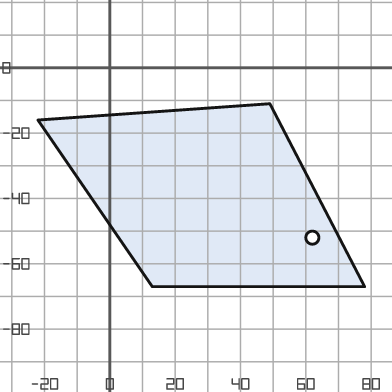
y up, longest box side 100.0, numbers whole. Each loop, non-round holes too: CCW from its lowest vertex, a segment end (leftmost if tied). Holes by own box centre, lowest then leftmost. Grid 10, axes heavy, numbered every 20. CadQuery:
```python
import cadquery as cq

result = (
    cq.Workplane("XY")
    .moveTo(13.0, -67.0)
    .lineTo(78.0, -67.0)
    .lineTo(49.0, -11.0)
    .lineTo(-22.0, -16.0)
    .close()
    .moveTo(62.0, -52.0)
    .circle(2.0)
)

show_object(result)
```